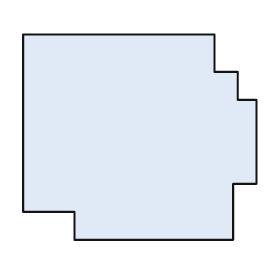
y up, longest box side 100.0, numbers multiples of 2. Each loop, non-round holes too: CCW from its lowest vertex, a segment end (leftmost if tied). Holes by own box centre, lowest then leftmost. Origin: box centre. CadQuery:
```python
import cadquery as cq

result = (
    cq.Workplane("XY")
    .moveTo(-28.0, -44.0)
    .lineTo(40.0, -44.0)
    .lineTo(40.0, -20.0)
    .lineTo(50.0, -20.0)
    .lineTo(50.0, 16.0)
    .lineTo(42.0, 16.0)
    .lineTo(42.0, 28.0)
    .lineTo(32.0, 28.0)
    .lineTo(32.0, 44.0)
    .lineTo(-50.0, 44.0)
    .lineTo(-50.0, -32.0)
    .lineTo(-28.0, -32.0)
    .close()
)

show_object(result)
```